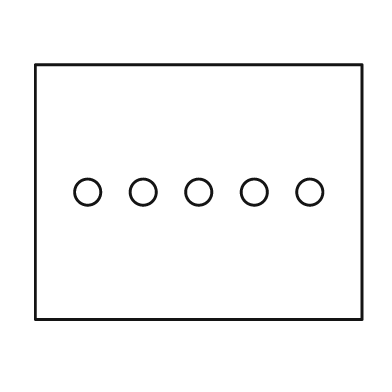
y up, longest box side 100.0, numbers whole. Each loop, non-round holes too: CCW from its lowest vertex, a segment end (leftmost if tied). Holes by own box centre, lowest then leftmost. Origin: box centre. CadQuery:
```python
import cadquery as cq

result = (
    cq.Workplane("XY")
    .moveTo(-50.0, -39.0)
    .lineTo(50.0, -39.0)
    .lineTo(50.0, 39.0)
    .lineTo(-50.0, 39.0)
    .close()
    .moveTo(-34.0, 0.0)
    .circle(4.0)
    .moveTo(-17.0, 0.0)
    .circle(4.0)
    .moveTo(0.0, 0.0)
    .circle(4.0)
    .moveTo(17.0, 0.0)
    .circle(4.0)
    .moveTo(34.0, 0.0)
    .circle(4.0)
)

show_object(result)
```